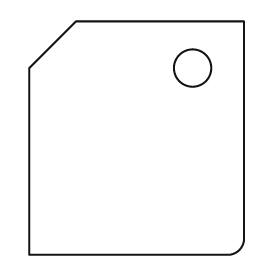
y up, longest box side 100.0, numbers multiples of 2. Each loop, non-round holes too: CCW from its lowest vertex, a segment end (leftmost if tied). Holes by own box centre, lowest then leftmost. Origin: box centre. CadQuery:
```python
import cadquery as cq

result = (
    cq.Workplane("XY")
    .moveTo(-46.0, -50.0)
    .lineTo(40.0, -50.0)
    .threePointArc((44.0, -48.0), (46.0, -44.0))
    .lineTo(46.0, 50.0)
    .lineTo(-26.0, 50.0)
    .lineTo(-46.0, 30.0)
    .close()
    .moveTo(24.0, 30.0)
    .circle(8.0)
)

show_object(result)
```